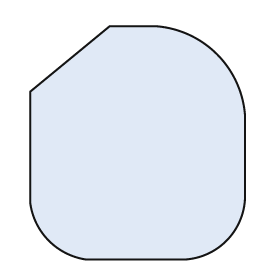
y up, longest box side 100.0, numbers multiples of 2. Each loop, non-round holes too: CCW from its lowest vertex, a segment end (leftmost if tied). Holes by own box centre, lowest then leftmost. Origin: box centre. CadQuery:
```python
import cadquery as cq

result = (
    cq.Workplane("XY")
    .moveTo(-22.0, -50.0)
    .lineTo(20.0, -50.0)
    .threePointArc((38.0, -42.0), (46.0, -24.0))
    .lineTo(46.0, 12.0)
    .threePointArc((34.0, 38.0), (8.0, 50.0))
    .lineTo(-12.0, 50.0)
    .lineTo(-46.0, 22.0)
    .lineTo(-46.0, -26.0)
    .threePointArc((-38.0, -42.0), (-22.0, -50.0))
    .close()
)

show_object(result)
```